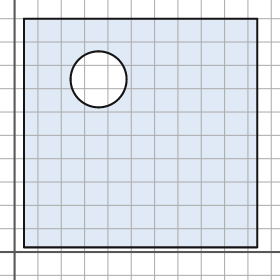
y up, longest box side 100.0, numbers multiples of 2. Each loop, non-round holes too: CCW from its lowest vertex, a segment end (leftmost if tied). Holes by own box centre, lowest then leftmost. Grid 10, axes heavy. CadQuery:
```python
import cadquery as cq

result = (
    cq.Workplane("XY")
    .moveTo(4.0, 2.0)
    .lineTo(104.0, 2.0)
    .lineTo(104.0, 100.0)
    .lineTo(4.0, 100.0)
    .close()
    .moveTo(36.0, 74.0)
    .circle(12.0)
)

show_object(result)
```